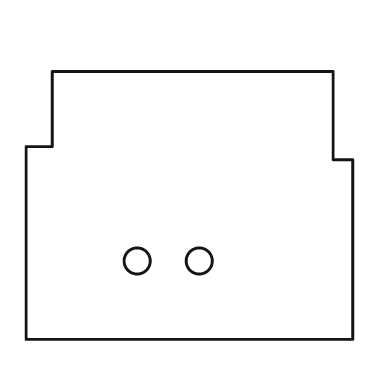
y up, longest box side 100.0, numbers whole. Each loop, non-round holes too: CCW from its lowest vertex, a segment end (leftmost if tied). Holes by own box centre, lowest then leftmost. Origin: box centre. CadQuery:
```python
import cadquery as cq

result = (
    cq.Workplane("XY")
    .moveTo(-50.0, -41.0)
    .lineTo(50.0, -41.0)
    .lineTo(50.0, 14.0)
    .lineTo(44.0, 14.0)
    .lineTo(44.0, 41.0)
    .lineTo(-42.0, 41.0)
    .lineTo(-42.0, 18.0)
    .lineTo(-50.0, 18.0)
    .close()
    .moveTo(-16.0, -17.0)
    .circle(4.0)
    .moveTo(3.0, -17.0)
    .circle(4.0)
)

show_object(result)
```